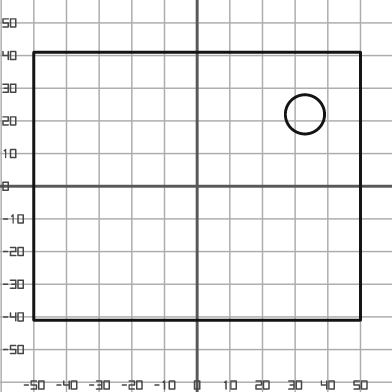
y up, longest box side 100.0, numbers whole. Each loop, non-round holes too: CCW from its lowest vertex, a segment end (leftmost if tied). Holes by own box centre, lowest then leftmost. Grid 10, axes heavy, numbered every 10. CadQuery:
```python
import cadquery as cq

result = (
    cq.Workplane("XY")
    .moveTo(-50.0, -41.0)
    .lineTo(50.0, -41.0)
    .lineTo(50.0, 41.0)
    .lineTo(-50.0, 41.0)
    .close()
    .moveTo(33.0, 22.0)
    .circle(6.0)
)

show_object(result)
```